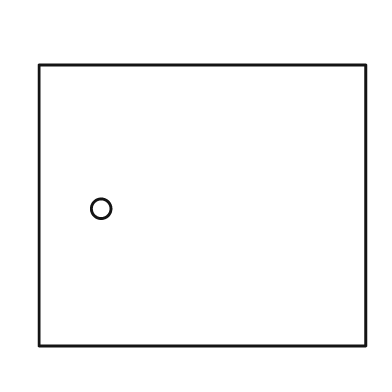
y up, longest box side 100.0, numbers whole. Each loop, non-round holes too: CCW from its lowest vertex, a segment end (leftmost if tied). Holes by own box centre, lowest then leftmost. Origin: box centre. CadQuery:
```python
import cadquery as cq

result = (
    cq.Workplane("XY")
    .moveTo(-50.0, -43.0)
    .lineTo(50.0, -43.0)
    .lineTo(50.0, 43.0)
    .lineTo(-50.0, 43.0)
    .close()
    .moveTo(-31.0, -1.0)
    .circle(3.0)
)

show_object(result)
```